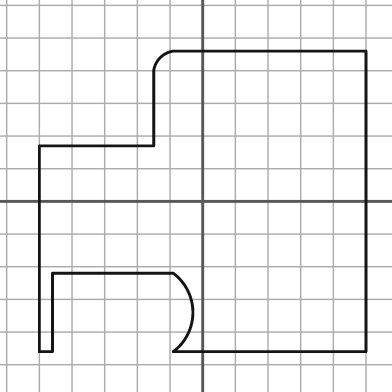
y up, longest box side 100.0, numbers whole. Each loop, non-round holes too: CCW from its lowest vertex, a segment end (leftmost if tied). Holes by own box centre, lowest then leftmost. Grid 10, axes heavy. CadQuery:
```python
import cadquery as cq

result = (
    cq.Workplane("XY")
    .moveTo(-50.0, -46.0)
    .lineTo(-46.0, -46.0)
    .lineTo(-46.0, -22.0)
    .lineTo(-9.0, -22.0)
    .threePointArc((-3.0, -34.0), (-9.0, -46.0))
    .lineTo(50.0, -46.0)
    .lineTo(50.0, 46.0)
    .lineTo(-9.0, 46.0)
    .threePointArc((-13.0, 44.0), (-15.0, 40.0))
    .lineTo(-15.0, 17.0)
    .lineTo(-50.0, 17.0)
    .close()
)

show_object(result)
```